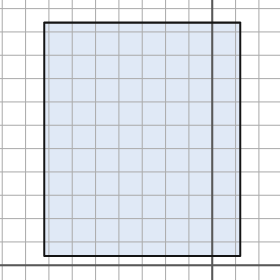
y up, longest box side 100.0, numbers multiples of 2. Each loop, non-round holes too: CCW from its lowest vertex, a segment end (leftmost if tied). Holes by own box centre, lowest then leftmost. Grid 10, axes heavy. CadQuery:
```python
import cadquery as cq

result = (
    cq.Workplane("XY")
    .moveTo(-72.0, 4.0)
    .lineTo(12.0, 4.0)
    .lineTo(12.0, 104.0)
    .lineTo(-72.0, 104.0)
    .close()
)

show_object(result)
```